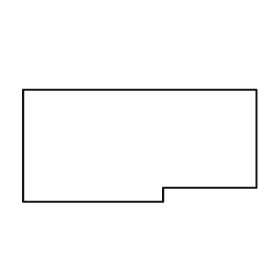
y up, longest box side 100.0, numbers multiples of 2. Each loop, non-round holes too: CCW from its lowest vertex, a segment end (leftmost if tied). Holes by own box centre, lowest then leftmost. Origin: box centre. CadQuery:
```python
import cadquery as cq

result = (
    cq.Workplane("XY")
    .moveTo(-50.0, -24.0)
    .lineTo(10.0, -24.0)
    .lineTo(10.0, -18.0)
    .lineTo(50.0, -18.0)
    .lineTo(50.0, 24.0)
    .lineTo(-50.0, 24.0)
    .close()
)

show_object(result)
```